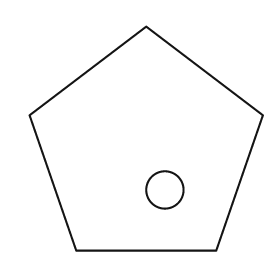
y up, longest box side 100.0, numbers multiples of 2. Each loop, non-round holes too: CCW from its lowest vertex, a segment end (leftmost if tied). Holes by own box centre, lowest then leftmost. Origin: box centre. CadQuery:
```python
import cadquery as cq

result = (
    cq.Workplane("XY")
    .moveTo(-30.0, -48.0)
    .lineTo(30.0, -48.0)
    .lineTo(50.0, 10.0)
    .lineTo(0.0, 48.0)
    .lineTo(-50.0, 10.0)
    .close()
    .moveTo(8.0, -22.0)
    .circle(8.0)
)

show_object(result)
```